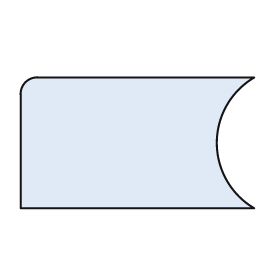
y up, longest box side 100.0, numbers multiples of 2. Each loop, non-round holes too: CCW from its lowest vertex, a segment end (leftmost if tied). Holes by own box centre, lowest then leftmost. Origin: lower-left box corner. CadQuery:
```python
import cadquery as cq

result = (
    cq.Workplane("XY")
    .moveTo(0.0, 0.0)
    .lineTo(100.0, 0.0)
    .threePointArc((84.0, 28.0), (100.0, 56.0))
    .lineTo(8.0, 56.0)
    .threePointArc((2.0, 54.0), (0.0, 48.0))
    .close()
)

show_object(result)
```